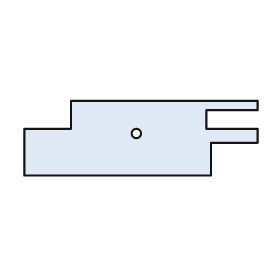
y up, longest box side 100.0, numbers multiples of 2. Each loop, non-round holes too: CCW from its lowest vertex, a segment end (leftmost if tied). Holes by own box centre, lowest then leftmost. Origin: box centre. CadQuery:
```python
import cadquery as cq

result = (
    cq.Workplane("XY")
    .moveTo(-50.0, -16.0)
    .lineTo(30.0, -16.0)
    .lineTo(30.0, -2.0)
    .lineTo(50.0, -2.0)
    .lineTo(50.0, 4.0)
    .lineTo(28.0, 4.0)
    .lineTo(28.0, 12.0)
    .lineTo(50.0, 12.0)
    .lineTo(50.0, 16.0)
    .lineTo(-30.0, 16.0)
    .lineTo(-30.0, 4.0)
    .lineTo(-50.0, 4.0)
    .close()
    .moveTo(-2.0, 2.0)
    .circle(2.0)
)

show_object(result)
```